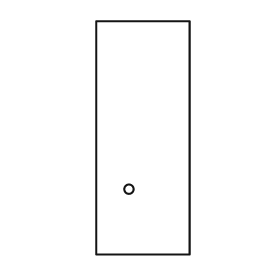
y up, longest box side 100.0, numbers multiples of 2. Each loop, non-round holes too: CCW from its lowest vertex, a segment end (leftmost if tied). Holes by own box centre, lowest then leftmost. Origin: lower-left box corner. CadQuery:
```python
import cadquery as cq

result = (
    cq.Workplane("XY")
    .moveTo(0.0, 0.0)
    .lineTo(40.0, 0.0)
    .lineTo(40.0, 100.0)
    .lineTo(0.0, 100.0)
    .close()
    .moveTo(14.0, 28.0)
    .circle(2.0)
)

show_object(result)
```